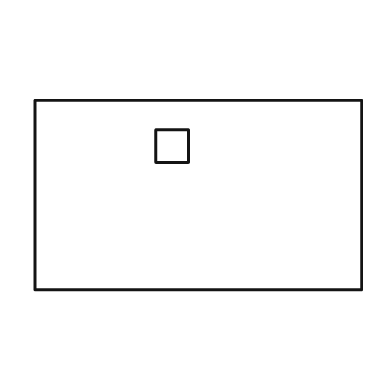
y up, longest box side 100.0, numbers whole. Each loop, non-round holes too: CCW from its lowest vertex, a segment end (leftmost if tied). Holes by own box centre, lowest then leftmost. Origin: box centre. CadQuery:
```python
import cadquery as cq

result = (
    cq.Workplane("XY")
    .moveTo(-50.0, -29.0)
    .lineTo(50.0, -29.0)
    .lineTo(50.0, 29.0)
    .lineTo(-50.0, 29.0)
    .close()
    .moveTo(-13.0, 10.0)
    .lineTo(-3.0, 10.0)
    .lineTo(-3.0, 20.0)
    .lineTo(-13.0, 20.0)
    .close()
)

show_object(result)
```